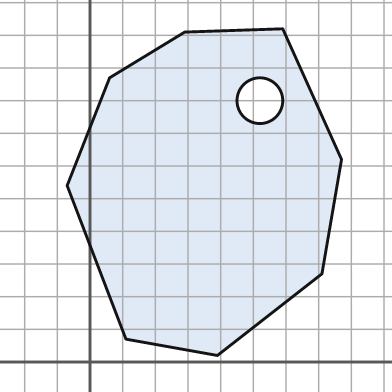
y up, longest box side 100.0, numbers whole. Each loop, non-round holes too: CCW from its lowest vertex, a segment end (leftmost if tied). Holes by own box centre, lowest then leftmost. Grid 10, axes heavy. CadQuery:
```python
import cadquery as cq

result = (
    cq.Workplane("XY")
    .moveTo(39.0, 2.0)
    .lineTo(71.0, 27.0)
    .lineTo(77.0, 62.0)
    .lineTo(59.0, 102.0)
    .lineTo(29.0, 101.0)
    .lineTo(6.0, 87.0)
    .lineTo(-7.0, 54.0)
    .lineTo(11.0, 7.0)
    .close()
    .moveTo(52.0, 80.0)
    .circle(7.0)
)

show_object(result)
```